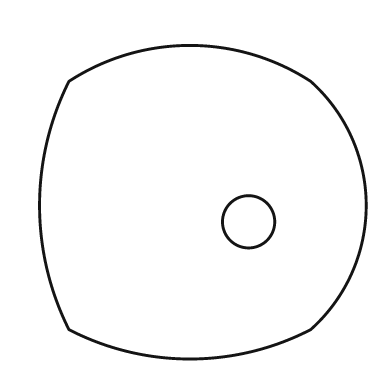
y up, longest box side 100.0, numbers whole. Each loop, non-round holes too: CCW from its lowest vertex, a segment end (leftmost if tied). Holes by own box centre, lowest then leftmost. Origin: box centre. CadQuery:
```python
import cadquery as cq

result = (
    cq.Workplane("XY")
    .moveTo(-41.0, -39.0)
    .threePointArc((-4.0, -48.0), (33.0, -39.0))
    .threePointArc((50.0, -1.0), (33.0, 37.0))
    .threePointArc((-4.0, 48.0), (-41.0, 37.0))
    .threePointArc((-50.0, -1.0), (-41.0, -39.0))
    .close()
    .moveTo(14.0, -6.0)
    .circle(8.0)
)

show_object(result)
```